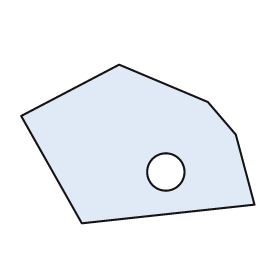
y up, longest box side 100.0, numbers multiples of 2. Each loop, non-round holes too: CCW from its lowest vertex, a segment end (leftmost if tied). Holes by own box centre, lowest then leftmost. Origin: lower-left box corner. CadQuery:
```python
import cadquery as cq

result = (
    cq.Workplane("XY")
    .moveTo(26.0, 0.0)
    .lineTo(100.0, 8.0)
    .lineTo(92.0, 38.0)
    .lineTo(80.0, 52.0)
    .lineTo(42.0, 68.0)
    .lineTo(0.0, 46.0)
    .close()
    .moveTo(62.0, 22.0)
    .circle(8.0)
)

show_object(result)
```